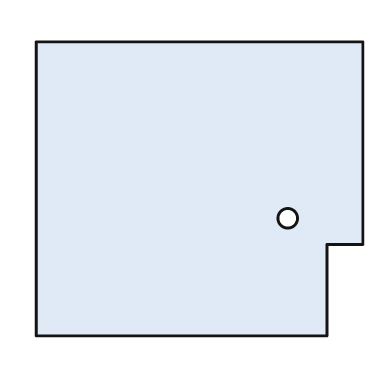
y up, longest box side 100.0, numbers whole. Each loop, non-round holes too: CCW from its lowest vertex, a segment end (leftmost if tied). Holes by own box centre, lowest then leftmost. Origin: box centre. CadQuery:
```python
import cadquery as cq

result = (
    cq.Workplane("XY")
    .moveTo(-50.0, -45.0)
    .lineTo(39.0, -45.0)
    .lineTo(39.0, -17.0)
    .lineTo(50.0, -17.0)
    .lineTo(50.0, 45.0)
    .lineTo(-50.0, 45.0)
    .close()
    .moveTo(27.0, -9.0)
    .circle(3.0)
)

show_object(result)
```